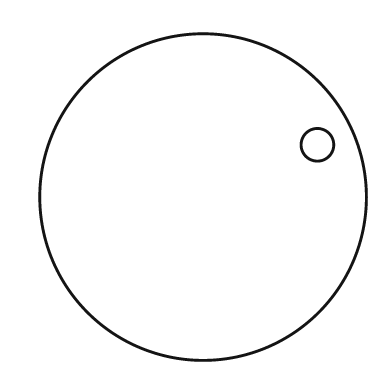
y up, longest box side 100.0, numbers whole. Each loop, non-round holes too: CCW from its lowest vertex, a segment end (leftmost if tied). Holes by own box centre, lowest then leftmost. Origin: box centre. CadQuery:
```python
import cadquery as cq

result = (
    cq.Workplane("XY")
    .moveTo(0.0, 0.0)
    .circle(50.0)
    .moveTo(35.0, 16.0)
    .circle(5.0)
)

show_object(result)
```